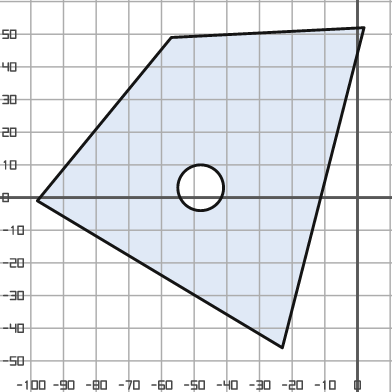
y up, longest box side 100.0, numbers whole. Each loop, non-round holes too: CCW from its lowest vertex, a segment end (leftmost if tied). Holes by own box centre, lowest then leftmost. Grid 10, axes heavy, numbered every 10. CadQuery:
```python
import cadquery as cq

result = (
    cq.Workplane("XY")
    .moveTo(-23.0, -46.0)
    .lineTo(2.0, 52.0)
    .lineTo(-57.0, 49.0)
    .lineTo(-98.0, -1.0)
    .close()
    .moveTo(-48.0, 3.0)
    .circle(7.0)
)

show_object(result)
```